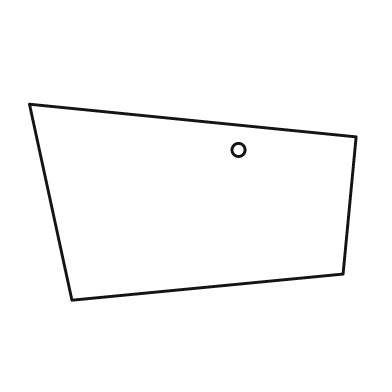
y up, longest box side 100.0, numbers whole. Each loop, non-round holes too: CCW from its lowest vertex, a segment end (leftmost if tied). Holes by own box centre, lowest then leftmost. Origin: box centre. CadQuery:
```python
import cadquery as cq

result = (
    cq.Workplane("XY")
    .moveTo(-37.0, -30.0)
    .lineTo(46.0, -22.0)
    .lineTo(50.0, 20.0)
    .lineTo(-50.0, 30.0)
    .close()
    .moveTo(14.0, 16.0)
    .circle(2.0)
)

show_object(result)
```